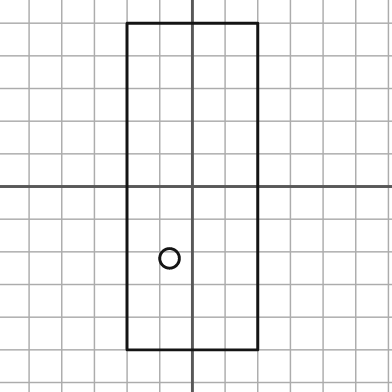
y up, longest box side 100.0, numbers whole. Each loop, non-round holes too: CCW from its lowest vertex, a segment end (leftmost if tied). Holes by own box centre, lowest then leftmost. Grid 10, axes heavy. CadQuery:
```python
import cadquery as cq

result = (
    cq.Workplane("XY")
    .moveTo(-20.0, -50.0)
    .lineTo(20.0, -50.0)
    .lineTo(20.0, 50.0)
    .lineTo(-20.0, 50.0)
    .close()
    .moveTo(-7.0, -22.0)
    .circle(3.0)
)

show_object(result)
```